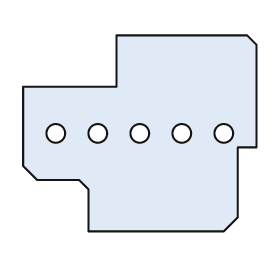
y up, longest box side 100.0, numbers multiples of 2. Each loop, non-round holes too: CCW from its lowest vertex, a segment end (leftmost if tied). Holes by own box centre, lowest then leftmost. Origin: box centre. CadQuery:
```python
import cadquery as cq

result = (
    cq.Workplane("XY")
    .moveTo(-22.0, -42.0)
    .lineTo(36.0, -42.0)
    .lineTo(42.0, -36.0)
    .lineTo(42.0, -6.0)
    .lineTo(50.0, -6.0)
    .lineTo(50.0, 38.0)
    .lineTo(46.0, 42.0)
    .lineTo(-10.0, 42.0)
    .lineTo(-10.0, 20.0)
    .lineTo(-50.0, 20.0)
    .lineTo(-50.0, -14.0)
    .lineTo(-44.0, -20.0)
    .lineTo(-26.0, -20.0)
    .lineTo(-22.0, -24.0)
    .close()
    .moveTo(-36.0, 0.0)
    .circle(4.0)
    .moveTo(-18.0, 0.0)
    .circle(4.0)
    .moveTo(0.0, 0.0)
    .circle(4.0)
    .moveTo(18.0, 0.0)
    .circle(4.0)
    .moveTo(36.0, 0.0)
    .circle(4.0)
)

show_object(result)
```